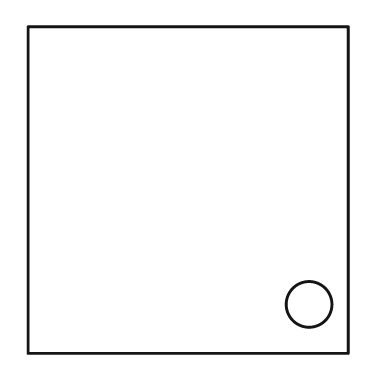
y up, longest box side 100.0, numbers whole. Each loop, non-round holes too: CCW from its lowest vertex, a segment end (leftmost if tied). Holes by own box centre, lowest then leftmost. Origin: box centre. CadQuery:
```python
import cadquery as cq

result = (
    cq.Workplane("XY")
    .moveTo(-49.0, -50.0)
    .lineTo(49.0, -50.0)
    .lineTo(49.0, 50.0)
    .lineTo(-49.0, 50.0)
    .close()
    .moveTo(37.0, -35.0)
    .circle(7.0)
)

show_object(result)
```